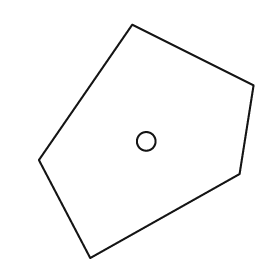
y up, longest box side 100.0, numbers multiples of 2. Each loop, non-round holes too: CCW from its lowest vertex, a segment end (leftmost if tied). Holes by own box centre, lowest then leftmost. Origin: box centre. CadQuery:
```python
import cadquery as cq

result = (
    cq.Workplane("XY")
    .moveTo(-24.0, -50.0)
    .lineTo(40.0, -14.0)
    .lineTo(46.0, 24.0)
    .lineTo(-6.0, 50.0)
    .lineTo(-46.0, -8.0)
    .close()
    .moveTo(0.0, 0.0)
    .circle(4.0)
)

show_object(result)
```